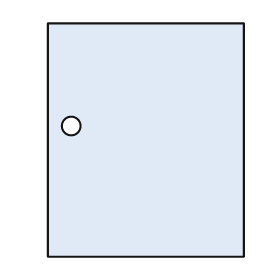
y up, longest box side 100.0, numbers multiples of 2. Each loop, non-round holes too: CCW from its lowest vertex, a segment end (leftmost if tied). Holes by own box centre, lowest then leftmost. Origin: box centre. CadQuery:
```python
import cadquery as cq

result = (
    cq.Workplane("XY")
    .moveTo(-42.0, -50.0)
    .lineTo(42.0, -50.0)
    .lineTo(42.0, 50.0)
    .lineTo(-42.0, 50.0)
    .close()
    .moveTo(-32.0, 6.0)
    .circle(4.0)
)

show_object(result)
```